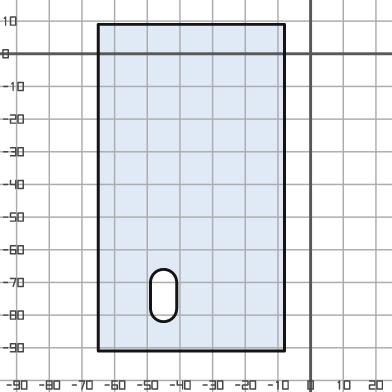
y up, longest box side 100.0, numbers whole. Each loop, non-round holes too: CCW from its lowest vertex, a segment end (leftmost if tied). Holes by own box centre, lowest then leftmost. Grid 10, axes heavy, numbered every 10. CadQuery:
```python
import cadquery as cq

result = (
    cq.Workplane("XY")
    .moveTo(-65.0, -91.0)
    .lineTo(-8.0, -91.0)
    .lineTo(-8.0, 9.0)
    .lineTo(-65.0, 9.0)
    .close()
    .moveTo(-49.0, -78.0)
    .threePointArc((-45.0, -82.0), (-41.0, -78.0))
    .lineTo(-41.0, -70.0)
    .threePointArc((-45.0, -66.0), (-49.0, -70.0))
    .close()
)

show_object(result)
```